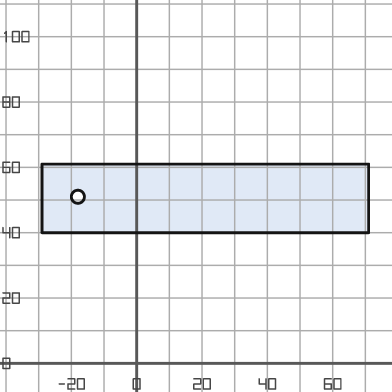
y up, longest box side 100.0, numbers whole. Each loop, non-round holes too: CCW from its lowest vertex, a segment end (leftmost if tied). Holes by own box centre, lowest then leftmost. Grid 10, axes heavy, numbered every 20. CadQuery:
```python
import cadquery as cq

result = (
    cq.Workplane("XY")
    .moveTo(-29.0, 40.0)
    .lineTo(71.0, 40.0)
    .lineTo(71.0, 61.0)
    .lineTo(-29.0, 61.0)
    .close()
    .moveTo(-18.0, 51.0)
    .circle(2.0)
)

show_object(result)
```